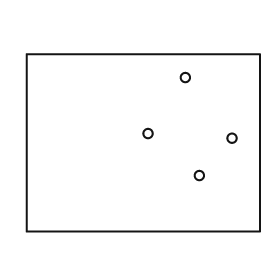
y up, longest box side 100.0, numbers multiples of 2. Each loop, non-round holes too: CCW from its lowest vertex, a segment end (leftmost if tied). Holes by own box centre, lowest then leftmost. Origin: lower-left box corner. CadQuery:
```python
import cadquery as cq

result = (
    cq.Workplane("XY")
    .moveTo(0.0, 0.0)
    .lineTo(100.0, 0.0)
    .lineTo(100.0, 76.0)
    .lineTo(0.0, 76.0)
    .close()
    .moveTo(74.0, 24.0)
    .circle(2.0)
    .moveTo(88.0, 40.0)
    .circle(2.0)
    .moveTo(52.0, 42.0)
    .circle(2.0)
    .moveTo(68.0, 66.0)
    .circle(2.0)
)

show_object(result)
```